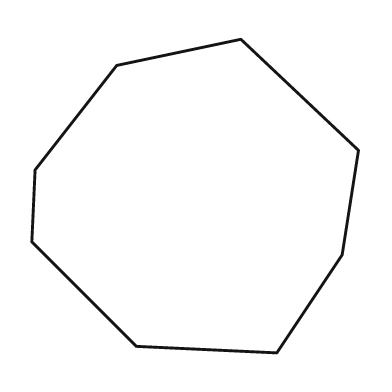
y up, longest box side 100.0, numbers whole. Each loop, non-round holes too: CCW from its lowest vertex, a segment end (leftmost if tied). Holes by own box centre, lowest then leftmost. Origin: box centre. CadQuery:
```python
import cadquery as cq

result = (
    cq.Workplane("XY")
    .moveTo(25.0, -48.0)
    .lineTo(45.0, -18.0)
    .lineTo(50.0, 14.0)
    .lineTo(14.0, 48.0)
    .lineTo(-24.0, 40.0)
    .lineTo(-49.0, 8.0)
    .lineTo(-50.0, -14.0)
    .lineTo(-18.0, -46.0)
    .close()
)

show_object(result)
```